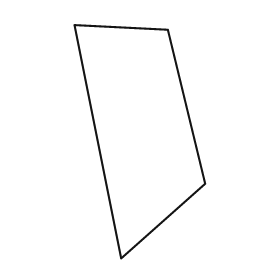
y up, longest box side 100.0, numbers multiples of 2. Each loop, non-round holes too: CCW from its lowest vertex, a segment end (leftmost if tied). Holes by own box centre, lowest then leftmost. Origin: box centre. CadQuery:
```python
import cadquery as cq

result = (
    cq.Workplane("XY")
    .moveTo(-8.0, -50.0)
    .lineTo(28.0, -18.0)
    .lineTo(12.0, 48.0)
    .lineTo(-28.0, 50.0)
    .close()
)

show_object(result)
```